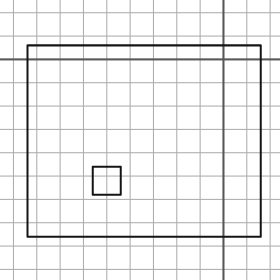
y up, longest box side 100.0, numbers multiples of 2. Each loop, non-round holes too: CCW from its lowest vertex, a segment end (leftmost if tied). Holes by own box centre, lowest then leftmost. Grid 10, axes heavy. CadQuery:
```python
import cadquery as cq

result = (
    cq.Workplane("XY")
    .moveTo(-84.0, -76.0)
    .lineTo(16.0, -76.0)
    .lineTo(16.0, 6.0)
    .lineTo(-84.0, 6.0)
    .close()
    .moveTo(-56.0, -58.0)
    .lineTo(-44.0, -58.0)
    .lineTo(-44.0, -46.0)
    .lineTo(-56.0, -46.0)
    .close()
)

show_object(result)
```